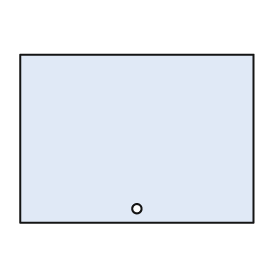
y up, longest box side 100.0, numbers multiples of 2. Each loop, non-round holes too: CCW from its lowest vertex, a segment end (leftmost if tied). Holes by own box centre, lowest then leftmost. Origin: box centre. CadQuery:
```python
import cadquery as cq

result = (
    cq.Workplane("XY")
    .moveTo(-50.0, -36.0)
    .lineTo(50.0, -36.0)
    .lineTo(50.0, 36.0)
    .lineTo(-50.0, 36.0)
    .close()
    .moveTo(0.0, -30.0)
    .circle(2.0)
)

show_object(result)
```